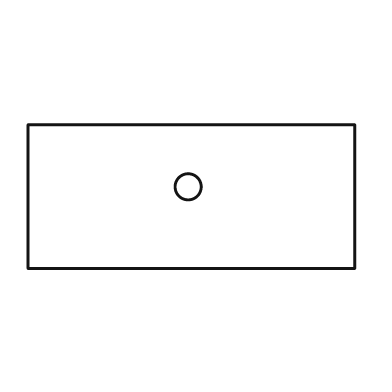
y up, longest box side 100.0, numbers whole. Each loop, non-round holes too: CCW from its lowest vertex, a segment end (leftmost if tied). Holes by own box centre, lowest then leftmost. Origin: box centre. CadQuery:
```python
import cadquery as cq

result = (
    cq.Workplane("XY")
    .moveTo(-50.0, -22.0)
    .lineTo(50.0, -22.0)
    .lineTo(50.0, 22.0)
    .lineTo(-50.0, 22.0)
    .close()
    .moveTo(-1.0, 3.0)
    .circle(4.0)
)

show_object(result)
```